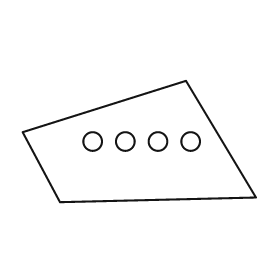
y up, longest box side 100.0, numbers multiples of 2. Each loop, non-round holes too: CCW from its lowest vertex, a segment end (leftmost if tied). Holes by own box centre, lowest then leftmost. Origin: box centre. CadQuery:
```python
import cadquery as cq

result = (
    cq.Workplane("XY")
    .moveTo(-34.0, -26.0)
    .lineTo(50.0, -24.0)
    .lineTo(20.0, 26.0)
    .lineTo(-50.0, 4.0)
    .close()
    .moveTo(-20.0, 0.0)
    .circle(4.0)
    .moveTo(-6.0, 0.0)
    .circle(4.0)
    .moveTo(8.0, 0.0)
    .circle(4.0)
    .moveTo(22.0, 0.0)
    .circle(4.0)
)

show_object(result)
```